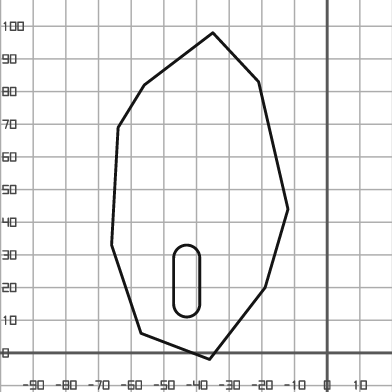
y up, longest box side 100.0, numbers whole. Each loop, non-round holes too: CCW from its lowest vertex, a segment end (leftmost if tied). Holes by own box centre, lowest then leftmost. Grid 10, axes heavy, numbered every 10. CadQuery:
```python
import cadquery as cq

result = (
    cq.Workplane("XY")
    .moveTo(-36.0, -2.0)
    .lineTo(-19.0, 20.0)
    .lineTo(-12.0, 44.0)
    .lineTo(-21.0, 83.0)
    .lineTo(-35.0, 98.0)
    .lineTo(-56.0, 82.0)
    .lineTo(-64.0, 69.0)
    .lineTo(-66.0, 33.0)
    .lineTo(-57.0, 6.0)
    .close()
    .moveTo(-47.0, 15.0)
    .threePointArc((-43.0, 11.0), (-39.0, 15.0))
    .lineTo(-39.0, 29.0)
    .threePointArc((-43.0, 33.0), (-47.0, 29.0))
    .close()
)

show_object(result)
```